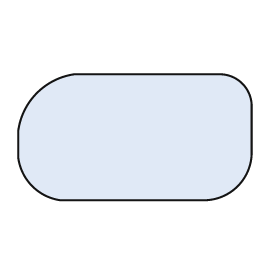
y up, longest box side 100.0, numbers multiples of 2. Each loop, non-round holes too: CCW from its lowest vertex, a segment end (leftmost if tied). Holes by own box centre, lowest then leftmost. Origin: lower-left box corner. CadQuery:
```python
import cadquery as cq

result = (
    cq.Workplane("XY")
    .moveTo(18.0, 0.0)
    .lineTo(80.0, 0.0)
    .threePointArc((94.0, 6.0), (100.0, 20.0))
    .lineTo(100.0, 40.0)
    .threePointArc((96.0, 50.0), (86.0, 54.0))
    .lineTo(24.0, 54.0)
    .threePointArc((8.0, 46.0), (0.0, 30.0))
    .lineTo(0.0, 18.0)
    .threePointArc((6.0, 6.0), (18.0, 0.0))
    .close()
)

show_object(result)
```